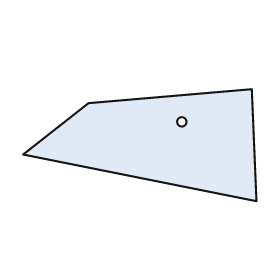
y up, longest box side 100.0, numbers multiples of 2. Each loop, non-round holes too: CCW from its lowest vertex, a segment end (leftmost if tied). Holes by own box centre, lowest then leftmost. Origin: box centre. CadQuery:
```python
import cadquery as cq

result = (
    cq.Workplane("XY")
    .moveTo(50.0, -24.0)
    .lineTo(48.0, 24.0)
    .lineTo(-22.0, 18.0)
    .lineTo(-50.0, -4.0)
    .close()
    .moveTo(18.0, 10.0)
    .circle(2.0)
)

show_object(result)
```